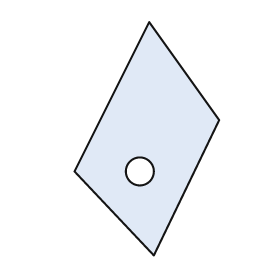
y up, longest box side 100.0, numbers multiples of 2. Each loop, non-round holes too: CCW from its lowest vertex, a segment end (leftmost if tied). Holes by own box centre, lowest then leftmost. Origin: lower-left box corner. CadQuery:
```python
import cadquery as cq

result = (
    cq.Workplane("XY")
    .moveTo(34.0, 0.0)
    .lineTo(62.0, 58.0)
    .lineTo(32.0, 100.0)
    .lineTo(0.0, 36.0)
    .close()
    .moveTo(28.0, 36.0)
    .circle(6.0)
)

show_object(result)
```